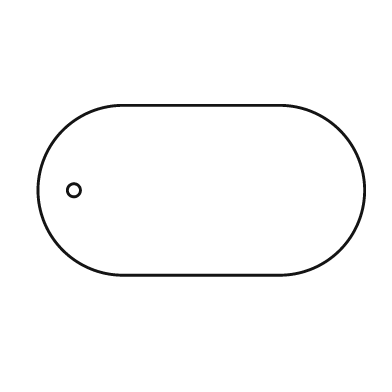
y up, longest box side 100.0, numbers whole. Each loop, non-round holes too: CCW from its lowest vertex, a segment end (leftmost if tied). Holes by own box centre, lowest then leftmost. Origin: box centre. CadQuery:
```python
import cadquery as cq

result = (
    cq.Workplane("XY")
    .moveTo(-24.0, -26.0)
    .lineTo(24.0, -26.0)
    .threePointArc((50.0, 0.0), (24.0, 26.0))
    .lineTo(-24.0, 26.0)
    .threePointArc((-50.0, 0.0), (-24.0, -26.0))
    .close()
    .moveTo(-39.0, 0.0)
    .circle(2.0)
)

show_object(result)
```